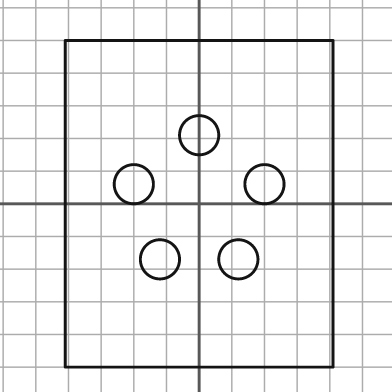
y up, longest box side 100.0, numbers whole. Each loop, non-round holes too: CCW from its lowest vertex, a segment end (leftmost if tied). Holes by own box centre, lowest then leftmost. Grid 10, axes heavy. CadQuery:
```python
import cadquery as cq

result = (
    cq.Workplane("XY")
    .moveTo(-41.0, -50.0)
    .lineTo(41.0, -50.0)
    .lineTo(41.0, 50.0)
    .lineTo(-41.0, 50.0)
    .close()
    .moveTo(-12.0, -17.0)
    .circle(6.0)
    .moveTo(12.0, -17.0)
    .circle(6.0)
    .moveTo(-20.0, 6.0)
    .circle(6.0)
    .moveTo(20.0, 6.0)
    .circle(6.0)
    .moveTo(0.0, 21.0)
    .circle(6.0)
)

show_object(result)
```